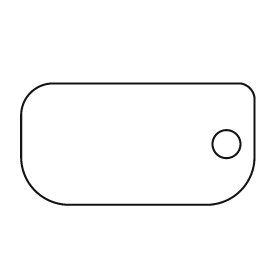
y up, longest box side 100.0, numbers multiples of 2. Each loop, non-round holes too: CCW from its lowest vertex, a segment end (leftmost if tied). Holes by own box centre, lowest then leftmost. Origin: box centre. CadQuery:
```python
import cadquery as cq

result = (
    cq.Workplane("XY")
    .moveTo(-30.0, -26.0)
    .lineTo(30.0, -26.0)
    .threePointArc((44.0, -20.0), (50.0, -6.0))
    .lineTo(50.0, 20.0)
    .threePointArc((48.0, 24.0), (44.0, 26.0))
    .lineTo(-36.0, 26.0)
    .threePointArc((-46.0, 22.0), (-50.0, 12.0))
    .lineTo(-50.0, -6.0)
    .threePointArc((-44.0, -20.0), (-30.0, -26.0))
    .close()
    .moveTo(38.0, 0.0)
    .circle(6.0)
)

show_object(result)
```